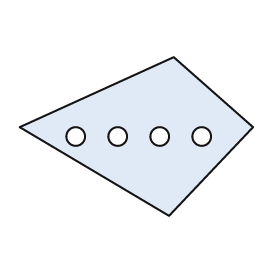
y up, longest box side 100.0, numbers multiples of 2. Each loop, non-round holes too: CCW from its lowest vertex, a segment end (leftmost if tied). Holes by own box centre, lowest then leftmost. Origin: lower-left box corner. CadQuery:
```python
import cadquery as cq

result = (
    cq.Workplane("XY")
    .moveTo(64.0, 0.0)
    .lineTo(100.0, 38.0)
    .lineTo(66.0, 68.0)
    .lineTo(0.0, 38.0)
    .close()
    .moveTo(24.0, 34.0)
    .circle(4.0)
    .moveTo(42.0, 34.0)
    .circle(4.0)
    .moveTo(60.0, 34.0)
    .circle(4.0)
    .moveTo(78.0, 34.0)
    .circle(4.0)
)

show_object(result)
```